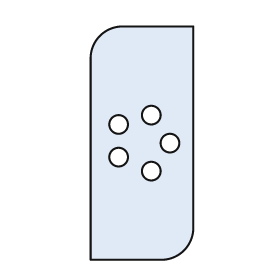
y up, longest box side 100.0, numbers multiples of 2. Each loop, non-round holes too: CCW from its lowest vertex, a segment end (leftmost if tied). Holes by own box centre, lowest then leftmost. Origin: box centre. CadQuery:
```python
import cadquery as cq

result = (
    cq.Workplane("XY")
    .moveTo(-22.0, -50.0)
    .lineTo(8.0, -50.0)
    .threePointArc((18.0, -46.0), (22.0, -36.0))
    .lineTo(22.0, 50.0)
    .lineTo(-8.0, 50.0)
    .threePointArc((-18.0, 46.0), (-22.0, 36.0))
    .close()
    .moveTo(4.0, -12.0)
    .circle(4.0)
    .moveTo(-10.0, -6.0)
    .circle(4.0)
    .moveTo(12.0, 0.0)
    .circle(4.0)
    .moveTo(-10.0, 8.0)
    .circle(4.0)
    .moveTo(4.0, 12.0)
    .circle(4.0)
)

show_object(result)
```